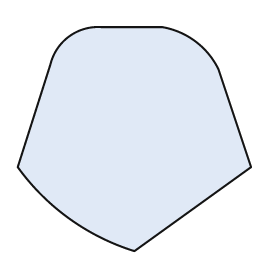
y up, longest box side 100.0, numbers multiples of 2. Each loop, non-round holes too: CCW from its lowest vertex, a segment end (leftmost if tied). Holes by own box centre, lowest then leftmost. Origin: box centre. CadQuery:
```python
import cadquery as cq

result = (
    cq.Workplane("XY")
    .moveTo(0.0, -48.0)
    .lineTo(50.0, -12.0)
    .lineTo(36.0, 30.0)
    .threePointArc((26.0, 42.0), (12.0, 48.0))
    .lineTo(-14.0, 48.0)
    .threePointArc((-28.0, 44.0), (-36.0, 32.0))
    .lineTo(-50.0, -12.0)
    .threePointArc((-28.0, -34.0), (0.0, -48.0))
    .close()
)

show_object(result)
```